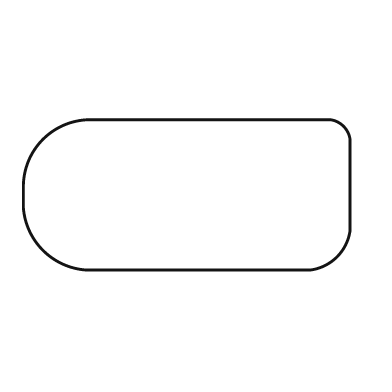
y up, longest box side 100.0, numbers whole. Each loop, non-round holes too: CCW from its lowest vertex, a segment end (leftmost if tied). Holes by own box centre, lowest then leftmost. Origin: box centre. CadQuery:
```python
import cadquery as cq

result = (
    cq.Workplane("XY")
    .moveTo(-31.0, -23.0)
    .lineTo(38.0, -23.0)
    .threePointArc((46.0, -19.0), (50.0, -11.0))
    .lineTo(50.0, 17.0)
    .threePointArc((48.0, 21.0), (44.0, 23.0))
    .lineTo(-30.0, 23.0)
    .threePointArc((-44.0, 17.0), (-50.0, 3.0))
    .lineTo(-50.0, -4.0)
    .threePointArc((-44.0, -17.0), (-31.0, -23.0))
    .close()
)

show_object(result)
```